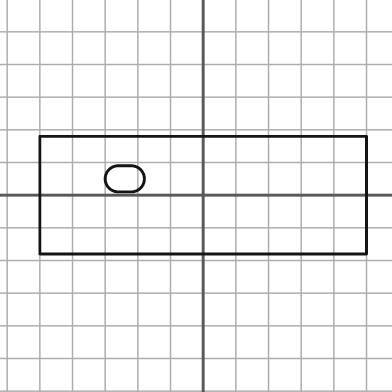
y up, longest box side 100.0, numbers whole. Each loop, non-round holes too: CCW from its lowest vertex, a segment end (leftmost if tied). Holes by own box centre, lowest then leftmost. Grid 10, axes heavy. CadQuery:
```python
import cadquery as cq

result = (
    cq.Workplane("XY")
    .moveTo(-50.0, -18.0)
    .lineTo(50.0, -18.0)
    .lineTo(50.0, 18.0)
    .lineTo(-50.0, 18.0)
    .close()
    .moveTo(-26.0, 1.0)
    .lineTo(-22.0, 1.0)
    .threePointArc((-18.0, 5.0), (-22.0, 9.0))
    .lineTo(-26.0, 9.0)
    .threePointArc((-30.0, 5.0), (-26.0, 1.0))
    .close()
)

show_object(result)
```